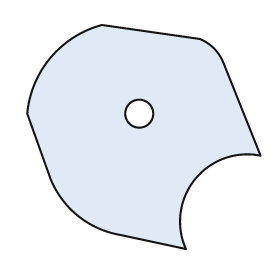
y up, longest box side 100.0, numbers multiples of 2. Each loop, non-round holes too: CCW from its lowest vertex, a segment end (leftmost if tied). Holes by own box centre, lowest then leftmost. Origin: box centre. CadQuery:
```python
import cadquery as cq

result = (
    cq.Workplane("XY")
    .moveTo(18.0, -48.0)
    .threePointArc((22.0, -18.0), (50.0, -8.0))
    .lineTo(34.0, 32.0)
    .threePointArc((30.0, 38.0), (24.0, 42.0))
    .lineTo(-18.0, 48.0)
    .threePointArc((-40.0, 34.0), (-50.0, 10.0))
    .lineTo(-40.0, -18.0)
    .threePointArc((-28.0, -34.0), (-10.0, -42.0))
    .close()
    .moveTo(-2.0, 10.0)
    .circle(6.0)
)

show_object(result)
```